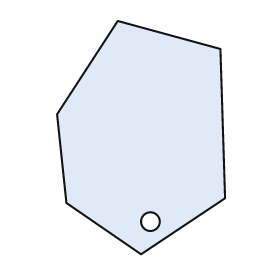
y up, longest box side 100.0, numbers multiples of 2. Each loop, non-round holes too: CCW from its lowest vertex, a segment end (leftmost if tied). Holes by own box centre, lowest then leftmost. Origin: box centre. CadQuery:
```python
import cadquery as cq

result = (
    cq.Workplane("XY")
    .moveTo(0.0, -50.0)
    .lineTo(36.0, -26.0)
    .lineTo(34.0, 38.0)
    .lineTo(-10.0, 50.0)
    .lineTo(-36.0, 10.0)
    .lineTo(-32.0, -28.0)
    .close()
    .moveTo(4.0, -36.0)
    .circle(4.0)
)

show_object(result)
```